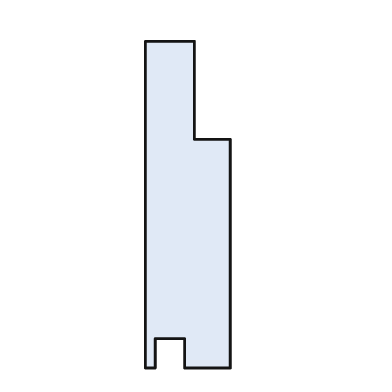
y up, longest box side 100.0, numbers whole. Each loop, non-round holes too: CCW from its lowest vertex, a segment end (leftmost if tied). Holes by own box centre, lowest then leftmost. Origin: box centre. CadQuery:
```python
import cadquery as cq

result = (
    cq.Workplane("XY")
    .moveTo(-13.0, -50.0)
    .lineTo(-10.0, -50.0)
    .lineTo(-10.0, -41.0)
    .lineTo(-1.0, -41.0)
    .lineTo(-1.0, -50.0)
    .lineTo(13.0, -50.0)
    .lineTo(13.0, 20.0)
    .lineTo(2.0, 20.0)
    .lineTo(2.0, 50.0)
    .lineTo(-13.0, 50.0)
    .close()
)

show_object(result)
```